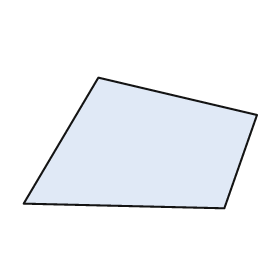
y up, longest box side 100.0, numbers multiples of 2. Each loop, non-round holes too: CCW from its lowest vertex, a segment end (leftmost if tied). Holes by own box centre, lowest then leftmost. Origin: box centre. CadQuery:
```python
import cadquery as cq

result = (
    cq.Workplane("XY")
    .moveTo(36.0, -28.0)
    .lineTo(50.0, 12.0)
    .lineTo(-18.0, 28.0)
    .lineTo(-50.0, -26.0)
    .close()
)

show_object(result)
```